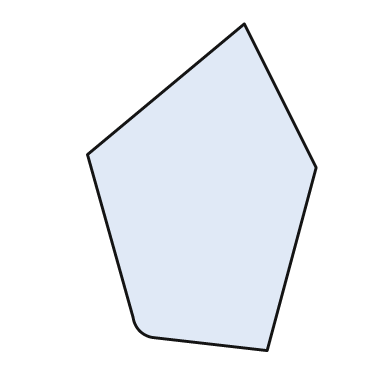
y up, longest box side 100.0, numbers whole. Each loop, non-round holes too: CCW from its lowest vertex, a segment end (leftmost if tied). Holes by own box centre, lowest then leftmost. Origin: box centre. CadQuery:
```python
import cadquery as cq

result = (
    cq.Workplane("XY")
    .moveTo(20.0, -50.0)
    .lineTo(35.0, 6.0)
    .lineTo(13.0, 50.0)
    .lineTo(-35.0, 10.0)
    .lineTo(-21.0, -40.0)
    .threePointArc((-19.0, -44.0), (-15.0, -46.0))
    .close()
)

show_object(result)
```